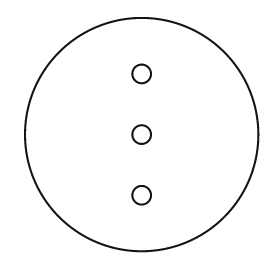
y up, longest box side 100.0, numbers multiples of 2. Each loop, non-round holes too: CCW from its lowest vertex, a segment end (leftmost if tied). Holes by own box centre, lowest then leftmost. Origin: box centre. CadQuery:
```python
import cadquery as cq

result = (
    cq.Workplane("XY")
    .moveTo(0.0, 0.0)
    .circle(50.0)
    .moveTo(0.0, -26.0)
    .circle(4.0)
    .moveTo(0.0, 0.0)
    .circle(4.0)
    .moveTo(0.0, 26.0)
    .circle(4.0)
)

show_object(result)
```